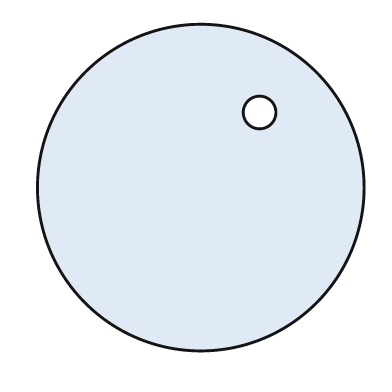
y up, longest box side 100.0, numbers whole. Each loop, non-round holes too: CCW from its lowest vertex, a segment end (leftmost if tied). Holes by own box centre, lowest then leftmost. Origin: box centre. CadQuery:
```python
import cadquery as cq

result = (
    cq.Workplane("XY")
    .moveTo(0.0, 0.0)
    .circle(50.0)
    .moveTo(18.0, 23.0)
    .circle(5.0)
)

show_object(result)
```